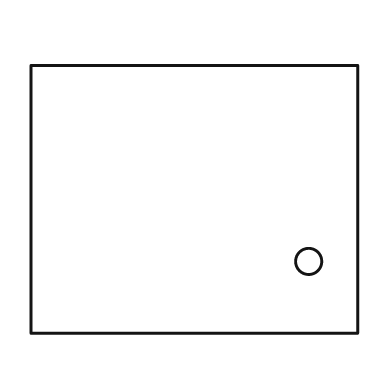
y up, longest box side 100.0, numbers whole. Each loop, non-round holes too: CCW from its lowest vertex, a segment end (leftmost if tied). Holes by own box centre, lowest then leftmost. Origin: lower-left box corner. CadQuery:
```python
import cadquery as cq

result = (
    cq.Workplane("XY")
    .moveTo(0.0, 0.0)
    .lineTo(100.0, 0.0)
    .lineTo(100.0, 82.0)
    .lineTo(0.0, 82.0)
    .close()
    .moveTo(85.0, 22.0)
    .circle(4.0)
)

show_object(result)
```